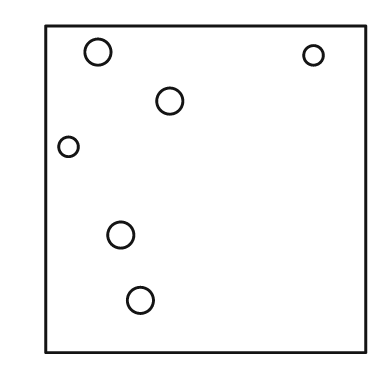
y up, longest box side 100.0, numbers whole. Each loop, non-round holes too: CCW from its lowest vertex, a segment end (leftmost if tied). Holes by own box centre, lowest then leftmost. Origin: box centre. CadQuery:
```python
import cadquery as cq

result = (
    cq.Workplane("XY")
    .moveTo(-49.0, -50.0)
    .lineTo(49.0, -50.0)
    .lineTo(49.0, 50.0)
    .lineTo(-49.0, 50.0)
    .close()
    .moveTo(-20.0, -34.0)
    .circle(4.0)
    .moveTo(-26.0, -14.0)
    .circle(4.0)
    .moveTo(-42.0, 13.0)
    .circle(3.0)
    .moveTo(-11.0, 27.0)
    .circle(4.0)
    .moveTo(33.0, 41.0)
    .circle(3.0)
    .moveTo(-33.0, 42.0)
    .circle(4.0)
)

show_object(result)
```